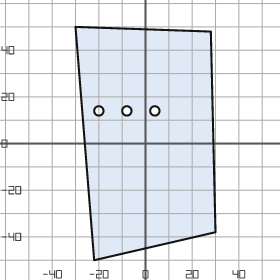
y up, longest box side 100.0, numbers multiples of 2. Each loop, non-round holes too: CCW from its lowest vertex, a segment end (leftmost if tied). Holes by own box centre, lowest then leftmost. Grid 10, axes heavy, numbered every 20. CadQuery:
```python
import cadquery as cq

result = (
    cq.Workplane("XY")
    .moveTo(-22.0, -50.0)
    .lineTo(30.0, -38.0)
    .lineTo(28.0, 48.0)
    .lineTo(-30.0, 50.0)
    .close()
    .moveTo(-20.0, 14.0)
    .circle(2.0)
    .moveTo(-8.0, 14.0)
    .circle(2.0)
    .moveTo(4.0, 14.0)
    .circle(2.0)
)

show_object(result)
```